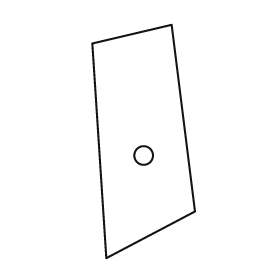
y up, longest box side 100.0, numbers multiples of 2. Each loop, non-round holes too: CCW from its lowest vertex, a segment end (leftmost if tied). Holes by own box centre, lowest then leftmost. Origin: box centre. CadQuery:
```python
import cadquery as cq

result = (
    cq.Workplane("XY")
    .moveTo(-16.0, -50.0)
    .lineTo(22.0, -30.0)
    .lineTo(12.0, 50.0)
    .lineTo(-22.0, 42.0)
    .close()
    .moveTo(0.0, -6.0)
    .circle(4.0)
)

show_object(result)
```